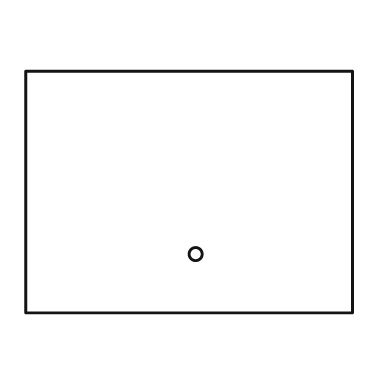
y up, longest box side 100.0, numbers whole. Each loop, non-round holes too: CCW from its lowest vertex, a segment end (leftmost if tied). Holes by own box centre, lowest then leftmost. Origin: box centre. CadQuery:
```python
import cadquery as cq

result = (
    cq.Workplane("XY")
    .moveTo(-50.0, -37.0)
    .lineTo(50.0, -37.0)
    .lineTo(50.0, 37.0)
    .lineTo(-50.0, 37.0)
    .close()
    .moveTo(2.0, -19.0)
    .circle(2.0)
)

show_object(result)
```